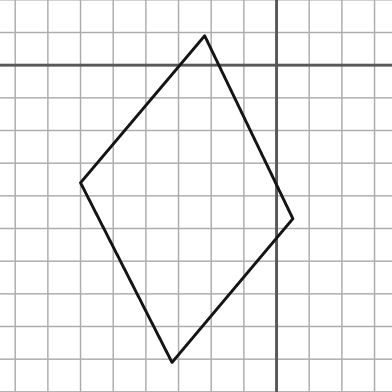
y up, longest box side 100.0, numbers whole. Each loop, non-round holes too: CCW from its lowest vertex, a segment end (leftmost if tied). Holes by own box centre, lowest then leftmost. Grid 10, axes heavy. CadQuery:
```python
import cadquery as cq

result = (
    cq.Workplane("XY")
    .moveTo(-32.0, -91.0)
    .lineTo(5.0, -47.0)
    .lineTo(-22.0, 9.0)
    .lineTo(-60.0, -36.0)
    .close()
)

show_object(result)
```